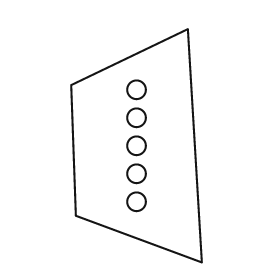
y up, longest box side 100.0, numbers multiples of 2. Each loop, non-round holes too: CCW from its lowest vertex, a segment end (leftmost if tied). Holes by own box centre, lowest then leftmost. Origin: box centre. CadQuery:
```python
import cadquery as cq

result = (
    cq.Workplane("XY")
    .moveTo(28.0, -50.0)
    .lineTo(22.0, 50.0)
    .lineTo(-28.0, 26.0)
    .lineTo(-26.0, -30.0)
    .close()
    .moveTo(0.0, -24.0)
    .circle(4.0)
    .moveTo(0.0, -12.0)
    .circle(4.0)
    .moveTo(0.0, 0.0)
    .circle(4.0)
    .moveTo(0.0, 12.0)
    .circle(4.0)
    .moveTo(0.0, 24.0)
    .circle(4.0)
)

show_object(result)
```